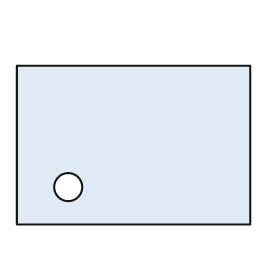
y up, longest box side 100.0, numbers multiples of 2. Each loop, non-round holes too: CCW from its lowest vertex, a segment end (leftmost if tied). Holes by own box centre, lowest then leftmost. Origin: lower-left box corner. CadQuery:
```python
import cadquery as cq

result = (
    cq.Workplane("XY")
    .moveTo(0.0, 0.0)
    .lineTo(100.0, 0.0)
    .lineTo(100.0, 68.0)
    .lineTo(0.0, 68.0)
    .close()
    .moveTo(22.0, 16.0)
    .circle(6.0)
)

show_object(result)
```